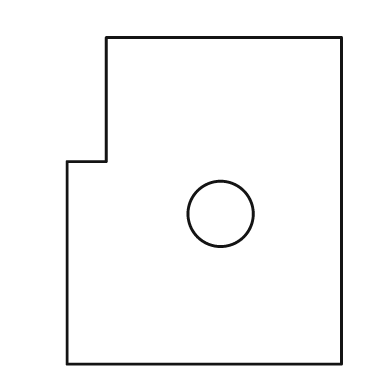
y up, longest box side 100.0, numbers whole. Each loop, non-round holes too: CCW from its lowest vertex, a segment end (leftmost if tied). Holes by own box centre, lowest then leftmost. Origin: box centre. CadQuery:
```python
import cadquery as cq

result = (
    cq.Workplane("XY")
    .moveTo(-42.0, -50.0)
    .lineTo(42.0, -50.0)
    .lineTo(42.0, 50.0)
    .lineTo(-30.0, 50.0)
    .lineTo(-30.0, 12.0)
    .lineTo(-42.0, 12.0)
    .close()
    .moveTo(5.0, -4.0)
    .circle(10.0)
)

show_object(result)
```